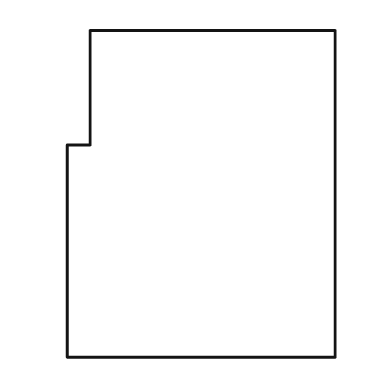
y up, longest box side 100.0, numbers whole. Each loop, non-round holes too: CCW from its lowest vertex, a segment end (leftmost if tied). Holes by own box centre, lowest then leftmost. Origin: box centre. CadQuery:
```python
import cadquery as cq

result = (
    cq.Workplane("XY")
    .moveTo(-41.0, -50.0)
    .lineTo(41.0, -50.0)
    .lineTo(41.0, 50.0)
    .lineTo(-34.0, 50.0)
    .lineTo(-34.0, 15.0)
    .lineTo(-41.0, 15.0)
    .close()
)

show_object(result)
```